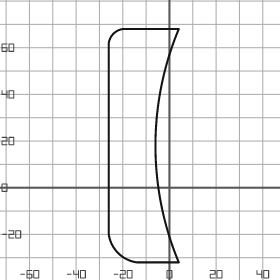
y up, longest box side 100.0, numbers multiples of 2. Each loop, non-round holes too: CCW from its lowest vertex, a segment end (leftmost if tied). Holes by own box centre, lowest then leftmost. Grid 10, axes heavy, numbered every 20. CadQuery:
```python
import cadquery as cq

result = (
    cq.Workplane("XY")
    .moveTo(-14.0, -32.0)
    .lineTo(4.0, -32.0)
    .threePointArc((-6.0, 18.0), (4.0, 68.0))
    .lineTo(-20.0, 68.0)
    .threePointArc((-24.0, 66.0), (-26.0, 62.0))
    .lineTo(-26.0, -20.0)
    .threePointArc((-22.0, -28.0), (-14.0, -32.0))
    .close()
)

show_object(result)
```